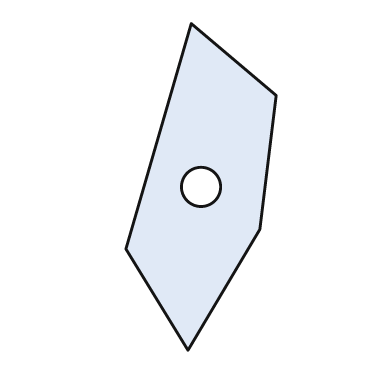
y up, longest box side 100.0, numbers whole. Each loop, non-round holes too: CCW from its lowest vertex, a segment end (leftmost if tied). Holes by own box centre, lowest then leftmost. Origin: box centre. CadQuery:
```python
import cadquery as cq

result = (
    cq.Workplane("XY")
    .moveTo(-4.0, -50.0)
    .lineTo(18.0, -13.0)
    .lineTo(23.0, 28.0)
    .lineTo(-3.0, 50.0)
    .lineTo(-23.0, -19.0)
    .close()
    .moveTo(0.0, 0.0)
    .circle(6.0)
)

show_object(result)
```